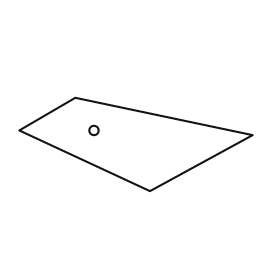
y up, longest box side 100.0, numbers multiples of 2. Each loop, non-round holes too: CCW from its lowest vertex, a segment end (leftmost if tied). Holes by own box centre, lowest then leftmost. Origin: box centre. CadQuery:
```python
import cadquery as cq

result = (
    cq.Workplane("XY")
    .moveTo(6.0, -20.0)
    .lineTo(50.0, 4.0)
    .lineTo(-26.0, 20.0)
    .lineTo(-50.0, 6.0)
    .close()
    .moveTo(-18.0, 6.0)
    .circle(2.0)
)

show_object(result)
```